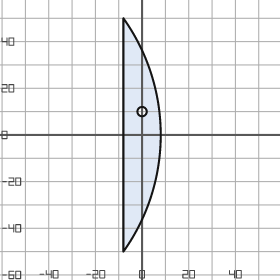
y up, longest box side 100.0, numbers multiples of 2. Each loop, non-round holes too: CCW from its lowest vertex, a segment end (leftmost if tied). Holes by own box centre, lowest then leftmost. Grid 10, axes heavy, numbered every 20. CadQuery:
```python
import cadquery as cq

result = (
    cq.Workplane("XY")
    .moveTo(-8.0, -50.0)
    .threePointArc((8.0, 0.0), (-8.0, 50.0))
    .close()
    .moveTo(0.0, 10.0)
    .circle(2.0)
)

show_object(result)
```